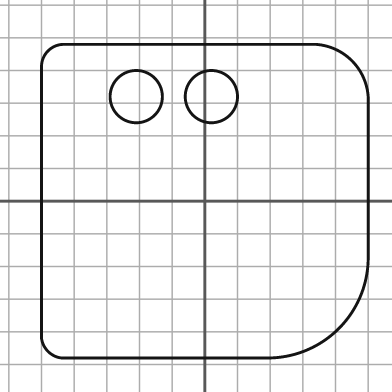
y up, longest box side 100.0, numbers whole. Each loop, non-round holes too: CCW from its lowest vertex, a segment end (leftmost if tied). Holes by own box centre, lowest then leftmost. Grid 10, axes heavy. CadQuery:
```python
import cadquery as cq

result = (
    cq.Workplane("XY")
    .moveTo(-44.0, -48.0)
    .lineTo(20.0, -48.0)
    .threePointArc((41.0, -39.0), (50.0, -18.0))
    .lineTo(50.0, 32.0)
    .threePointArc((45.0, 43.0), (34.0, 48.0))
    .lineTo(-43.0, 48.0)
    .threePointArc((-48.0, 46.0), (-50.0, 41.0))
    .lineTo(-50.0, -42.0)
    .threePointArc((-48.0, -46.0), (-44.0, -48.0))
    .close()
    .moveTo(-21.0, 32.0)
    .circle(8.0)
    .moveTo(2.0, 32.0)
    .circle(8.0)
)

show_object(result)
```